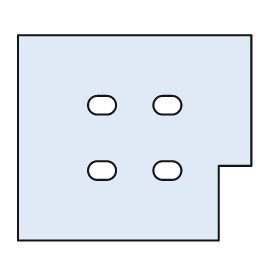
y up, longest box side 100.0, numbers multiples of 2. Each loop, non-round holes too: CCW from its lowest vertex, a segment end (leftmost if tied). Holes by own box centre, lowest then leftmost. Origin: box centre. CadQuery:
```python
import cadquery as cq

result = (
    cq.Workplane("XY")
    .moveTo(-50.0, -44.0)
    .lineTo(36.0, -44.0)
    .lineTo(36.0, -12.0)
    .lineTo(50.0, -12.0)
    .lineTo(50.0, 44.0)
    .lineTo(-50.0, 44.0)
    .close()
    .moveTo(-16.0, -18.0)
    .lineTo(-12.0, -18.0)
    .threePointArc((-8.0, -14.0), (-12.0, -10.0))
    .lineTo(-16.0, -10.0)
    .threePointArc((-20.0, -14.0), (-16.0, -18.0))
    .close()
    .moveTo(12.0, -18.0)
    .lineTo(16.0, -18.0)
    .threePointArc((20.0, -14.0), (16.0, -10.0))
    .lineTo(12.0, -10.0)
    .threePointArc((8.0, -14.0), (12.0, -18.0))
    .close()
    .moveTo(-16.0, 10.0)
    .lineTo(-12.0, 10.0)
    .threePointArc((-8.0, 14.0), (-12.0, 18.0))
    .lineTo(-16.0, 18.0)
    .threePointArc((-20.0, 14.0), (-16.0, 10.0))
    .close()
    .moveTo(12.0, 10.0)
    .lineTo(16.0, 10.0)
    .threePointArc((20.0, 14.0), (16.0, 18.0))
    .lineTo(12.0, 18.0)
    .threePointArc((8.0, 14.0), (12.0, 10.0))
    .close()
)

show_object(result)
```